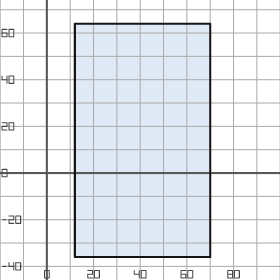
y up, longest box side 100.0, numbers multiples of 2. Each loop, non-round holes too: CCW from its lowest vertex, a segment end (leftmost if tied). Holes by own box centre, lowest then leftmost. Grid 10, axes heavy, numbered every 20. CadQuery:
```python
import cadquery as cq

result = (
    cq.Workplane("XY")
    .moveTo(12.0, -36.0)
    .lineTo(70.0, -36.0)
    .lineTo(70.0, 64.0)
    .lineTo(12.0, 64.0)
    .close()
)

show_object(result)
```